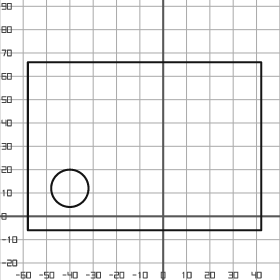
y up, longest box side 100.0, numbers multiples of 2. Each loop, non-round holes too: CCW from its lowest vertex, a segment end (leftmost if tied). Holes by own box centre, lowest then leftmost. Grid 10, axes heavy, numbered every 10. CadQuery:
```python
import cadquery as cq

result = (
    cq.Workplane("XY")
    .moveTo(-58.0, -6.0)
    .lineTo(42.0, -6.0)
    .lineTo(42.0, 66.0)
    .lineTo(-58.0, 66.0)
    .close()
    .moveTo(-40.0, 12.0)
    .circle(8.0)
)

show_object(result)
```